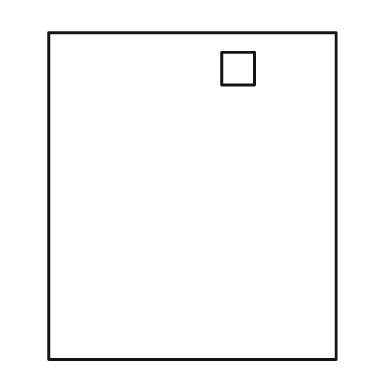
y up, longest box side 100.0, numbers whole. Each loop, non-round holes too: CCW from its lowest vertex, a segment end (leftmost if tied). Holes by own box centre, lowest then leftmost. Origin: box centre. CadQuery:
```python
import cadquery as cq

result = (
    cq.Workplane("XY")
    .moveTo(-44.0, -50.0)
    .lineTo(44.0, -50.0)
    .lineTo(44.0, 50.0)
    .lineTo(-44.0, 50.0)
    .close()
    .moveTo(9.0, 34.0)
    .lineTo(19.0, 34.0)
    .lineTo(19.0, 44.0)
    .lineTo(9.0, 44.0)
    .close()
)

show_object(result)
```